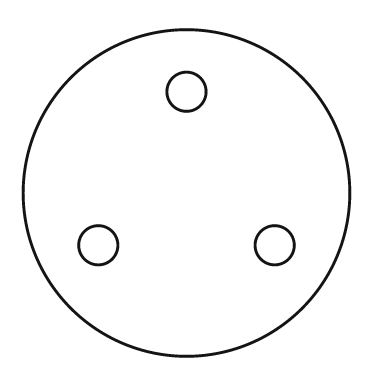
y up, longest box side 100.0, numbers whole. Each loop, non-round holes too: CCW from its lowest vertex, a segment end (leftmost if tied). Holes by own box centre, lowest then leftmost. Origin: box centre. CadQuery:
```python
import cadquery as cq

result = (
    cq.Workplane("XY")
    .moveTo(0.0, 0.0)
    .circle(50.0)
    .moveTo(-27.0, -16.0)
    .circle(6.0)
    .moveTo(27.0, -16.0)
    .circle(6.0)
    .moveTo(0.0, 31.0)
    .circle(6.0)
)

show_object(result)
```